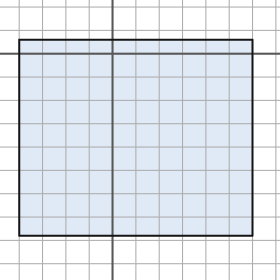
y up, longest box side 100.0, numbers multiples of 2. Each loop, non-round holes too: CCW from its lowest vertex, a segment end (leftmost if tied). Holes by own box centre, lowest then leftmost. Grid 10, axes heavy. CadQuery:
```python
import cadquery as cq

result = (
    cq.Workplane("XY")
    .moveTo(-40.0, -78.0)
    .lineTo(60.0, -78.0)
    .lineTo(60.0, 6.0)
    .lineTo(-40.0, 6.0)
    .close()
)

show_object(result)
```